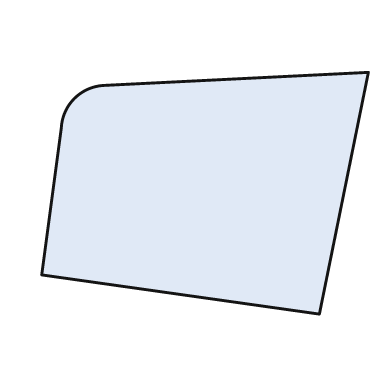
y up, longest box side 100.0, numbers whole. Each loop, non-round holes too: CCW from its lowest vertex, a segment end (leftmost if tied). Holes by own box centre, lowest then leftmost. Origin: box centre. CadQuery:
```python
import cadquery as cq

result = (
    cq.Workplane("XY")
    .moveTo(35.0, -37.0)
    .lineTo(50.0, 37.0)
    .lineTo(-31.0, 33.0)
    .threePointArc((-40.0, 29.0), (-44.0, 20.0))
    .lineTo(-50.0, -25.0)
    .close()
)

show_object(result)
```